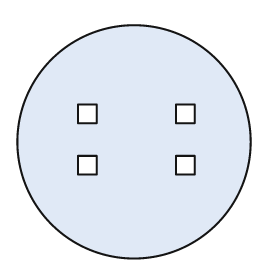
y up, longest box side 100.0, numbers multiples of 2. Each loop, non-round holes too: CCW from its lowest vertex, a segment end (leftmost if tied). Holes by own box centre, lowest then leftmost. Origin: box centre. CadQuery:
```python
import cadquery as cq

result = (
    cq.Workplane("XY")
    .moveTo(0.0, 0.0)
    .circle(50.0)
    .moveTo(-24.0, -14.0)
    .lineTo(-16.0, -14.0)
    .lineTo(-16.0, -6.0)
    .lineTo(-24.0, -6.0)
    .close()
    .moveTo(18.0, -14.0)
    .lineTo(26.0, -14.0)
    .lineTo(26.0, -6.0)
    .lineTo(18.0, -6.0)
    .close()
    .moveTo(-24.0, 8.0)
    .lineTo(-16.0, 8.0)
    .lineTo(-16.0, 16.0)
    .lineTo(-24.0, 16.0)
    .close()
    .moveTo(18.0, 8.0)
    .lineTo(26.0, 8.0)
    .lineTo(26.0, 16.0)
    .lineTo(18.0, 16.0)
    .close()
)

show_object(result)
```